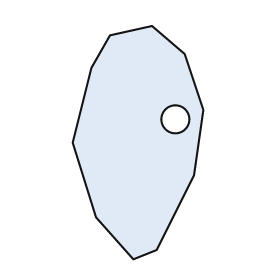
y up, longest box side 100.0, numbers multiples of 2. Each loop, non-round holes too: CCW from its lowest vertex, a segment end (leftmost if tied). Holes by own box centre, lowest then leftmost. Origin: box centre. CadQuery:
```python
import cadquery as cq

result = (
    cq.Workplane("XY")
    .moveTo(-2.0, -50.0)
    .lineTo(8.0, -46.0)
    .lineTo(24.0, -14.0)
    .lineTo(28.0, 14.0)
    .lineTo(20.0, 38.0)
    .lineTo(6.0, 50.0)
    .lineTo(-12.0, 46.0)
    .lineTo(-20.0, 32.0)
    .lineTo(-28.0, 0.0)
    .lineTo(-18.0, -32.0)
    .close()
    .moveTo(16.0, 10.0)
    .circle(6.0)
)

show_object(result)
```